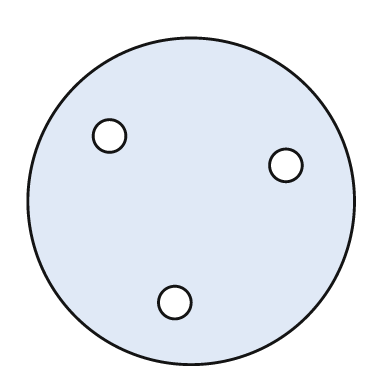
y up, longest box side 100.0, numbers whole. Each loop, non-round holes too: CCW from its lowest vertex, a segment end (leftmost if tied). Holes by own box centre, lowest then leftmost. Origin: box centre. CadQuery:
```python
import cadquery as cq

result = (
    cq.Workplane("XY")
    .moveTo(0.0, 0.0)
    .circle(50.0)
    .moveTo(-5.0, -31.0)
    .circle(5.0)
    .moveTo(29.0, 11.0)
    .circle(5.0)
    .moveTo(-25.0, 20.0)
    .circle(5.0)
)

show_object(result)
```